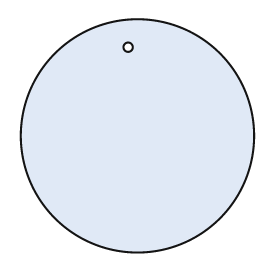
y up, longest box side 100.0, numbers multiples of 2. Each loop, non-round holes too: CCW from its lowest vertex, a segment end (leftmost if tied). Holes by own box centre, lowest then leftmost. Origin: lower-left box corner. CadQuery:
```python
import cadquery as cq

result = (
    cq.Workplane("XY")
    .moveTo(50.0, 50.0)
    .circle(50.0)
    .moveTo(46.0, 88.0)
    .circle(2.0)
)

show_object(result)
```